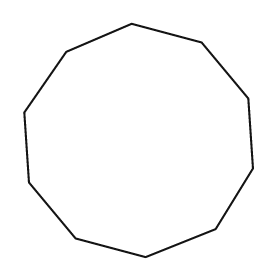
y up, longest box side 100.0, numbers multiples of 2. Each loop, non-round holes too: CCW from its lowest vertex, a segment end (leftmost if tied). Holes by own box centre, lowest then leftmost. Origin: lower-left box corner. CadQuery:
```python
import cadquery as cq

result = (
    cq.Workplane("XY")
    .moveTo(52.0, 0.0)
    .lineTo(82.0, 12.0)
    .lineTo(98.0, 38.0)
    .lineTo(96.0, 68.0)
    .lineTo(76.0, 92.0)
    .lineTo(46.0, 100.0)
    .lineTo(18.0, 88.0)
    .lineTo(0.0, 62.0)
    .lineTo(2.0, 32.0)
    .lineTo(22.0, 8.0)
    .close()
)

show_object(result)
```